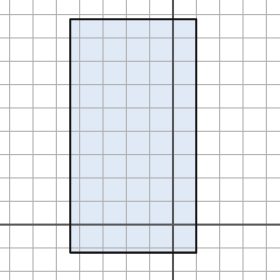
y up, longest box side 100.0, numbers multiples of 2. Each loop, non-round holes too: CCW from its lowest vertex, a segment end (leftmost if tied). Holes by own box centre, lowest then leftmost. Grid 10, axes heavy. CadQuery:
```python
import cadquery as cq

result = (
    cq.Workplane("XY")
    .moveTo(-44.0, -12.0)
    .lineTo(10.0, -12.0)
    .lineTo(10.0, 88.0)
    .lineTo(-44.0, 88.0)
    .close()
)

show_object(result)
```